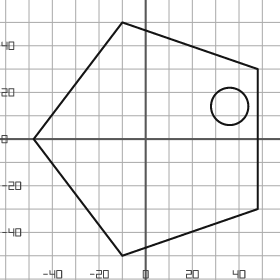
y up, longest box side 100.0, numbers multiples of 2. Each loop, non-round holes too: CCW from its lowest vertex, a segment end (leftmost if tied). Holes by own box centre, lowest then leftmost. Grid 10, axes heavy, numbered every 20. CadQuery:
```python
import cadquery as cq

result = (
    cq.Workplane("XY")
    .moveTo(-10.0, -50.0)
    .lineTo(48.0, -30.0)
    .lineTo(48.0, 30.0)
    .lineTo(-10.0, 50.0)
    .lineTo(-48.0, 0.0)
    .close()
    .moveTo(36.0, 14.0)
    .circle(8.0)
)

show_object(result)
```